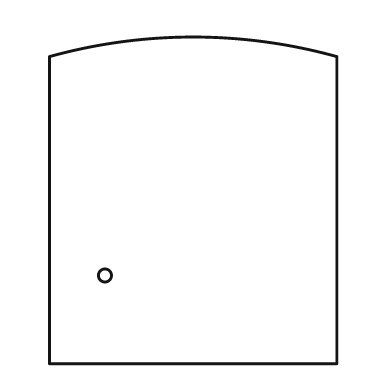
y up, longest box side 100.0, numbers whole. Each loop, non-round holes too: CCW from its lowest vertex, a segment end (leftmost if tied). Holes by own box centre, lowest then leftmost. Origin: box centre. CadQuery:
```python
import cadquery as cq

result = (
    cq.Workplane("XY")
    .moveTo(-44.0, -50.0)
    .lineTo(44.0, -50.0)
    .lineTo(44.0, 44.0)
    .threePointArc((0.0, 50.0), (-44.0, 44.0))
    .close()
    .moveTo(-27.0, -23.0)
    .circle(2.0)
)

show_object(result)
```